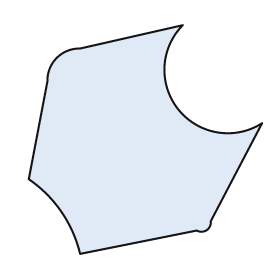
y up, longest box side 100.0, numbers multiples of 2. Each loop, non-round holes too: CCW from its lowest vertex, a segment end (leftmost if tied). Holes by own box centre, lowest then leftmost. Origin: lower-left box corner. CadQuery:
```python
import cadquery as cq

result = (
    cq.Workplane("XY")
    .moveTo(22.0, 0.0)
    .lineTo(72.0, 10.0)
    .threePointArc((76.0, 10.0), (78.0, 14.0))
    .lineTo(100.0, 56.0)
    .threePointArc((64.0, 62.0), (66.0, 98.0))
    .lineTo(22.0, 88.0)
    .threePointArc((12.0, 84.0), (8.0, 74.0))
    .lineTo(0.0, 32.0)
    .threePointArc((14.0, 18.0), (22.0, 0.0))
    .close()
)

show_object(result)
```